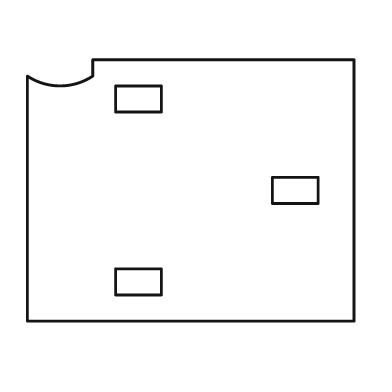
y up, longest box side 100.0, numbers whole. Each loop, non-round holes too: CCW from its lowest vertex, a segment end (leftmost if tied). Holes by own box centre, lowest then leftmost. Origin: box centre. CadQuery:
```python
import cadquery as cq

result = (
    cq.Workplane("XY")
    .moveTo(-50.0, -40.0)
    .lineTo(50.0, -40.0)
    .lineTo(50.0, 40.0)
    .lineTo(-30.0, 40.0)
    .lineTo(-30.0, 35.0)
    .threePointArc((-40.0, 32.0), (-50.0, 35.0))
    .close()
    .moveTo(-23.0, -32.0)
    .lineTo(-9.0, -32.0)
    .lineTo(-9.0, -24.0)
    .lineTo(-23.0, -24.0)
    .close()
    .moveTo(25.0, -4.0)
    .lineTo(39.0, -4.0)
    .lineTo(39.0, 4.0)
    .lineTo(25.0, 4.0)
    .close()
    .moveTo(-23.0, 24.0)
    .lineTo(-9.0, 24.0)
    .lineTo(-9.0, 32.0)
    .lineTo(-23.0, 32.0)
    .close()
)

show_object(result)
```